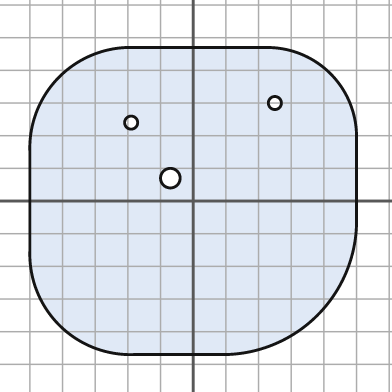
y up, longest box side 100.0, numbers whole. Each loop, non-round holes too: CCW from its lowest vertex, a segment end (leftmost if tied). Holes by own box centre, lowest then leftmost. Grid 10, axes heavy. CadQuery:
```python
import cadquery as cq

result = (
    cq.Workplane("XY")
    .moveTo(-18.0, -47.0)
    .lineTo(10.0, -47.0)
    .threePointArc((38.0, -35.0), (50.0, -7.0))
    .lineTo(50.0, 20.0)
    .threePointArc((42.0, 39.0), (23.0, 47.0))
    .lineTo(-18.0, 47.0)
    .threePointArc((-41.0, 38.0), (-50.0, 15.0))
    .lineTo(-50.0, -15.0)
    .threePointArc((-41.0, -38.0), (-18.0, -47.0))
    .close()
    .moveTo(-7.0, 7.0)
    .circle(3.0)
    .moveTo(-19.0, 24.0)
    .circle(2.0)
    .moveTo(25.0, 30.0)
    .circle(2.0)
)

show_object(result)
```